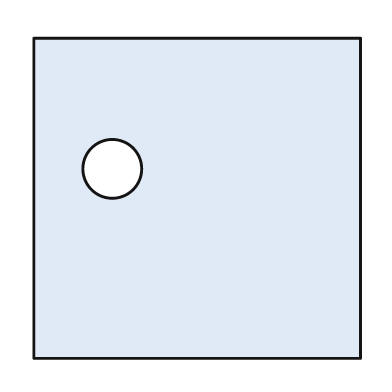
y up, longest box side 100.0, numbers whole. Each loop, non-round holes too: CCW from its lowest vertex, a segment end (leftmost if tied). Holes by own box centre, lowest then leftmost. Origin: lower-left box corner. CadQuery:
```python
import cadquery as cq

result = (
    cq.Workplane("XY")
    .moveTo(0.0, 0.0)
    .lineTo(100.0, 0.0)
    .lineTo(100.0, 98.0)
    .lineTo(0.0, 98.0)
    .close()
    .moveTo(24.0, 58.0)
    .circle(9.0)
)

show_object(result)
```